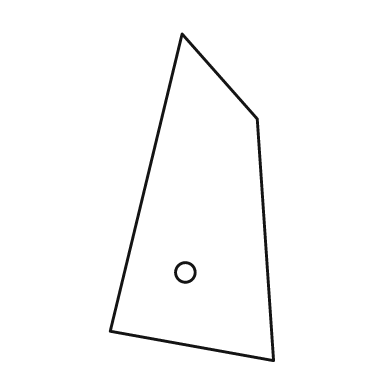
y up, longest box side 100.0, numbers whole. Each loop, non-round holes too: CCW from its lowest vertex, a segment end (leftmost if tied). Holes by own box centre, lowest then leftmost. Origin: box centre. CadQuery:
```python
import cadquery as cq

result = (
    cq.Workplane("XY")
    .moveTo(25.0, -50.0)
    .lineTo(20.0, 24.0)
    .lineTo(-3.0, 50.0)
    .lineTo(-25.0, -41.0)
    .close()
    .moveTo(-2.0, -23.0)
    .circle(3.0)
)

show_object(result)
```